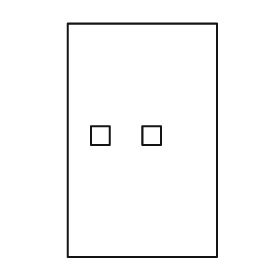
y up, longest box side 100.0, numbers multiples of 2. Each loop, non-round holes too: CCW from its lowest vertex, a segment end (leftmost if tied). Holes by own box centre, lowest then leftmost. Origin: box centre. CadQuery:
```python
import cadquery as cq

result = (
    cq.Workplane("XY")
    .moveTo(-32.0, -50.0)
    .lineTo(32.0, -50.0)
    .lineTo(32.0, 50.0)
    .lineTo(-32.0, 50.0)
    .close()
    .moveTo(-22.0, -2.0)
    .lineTo(-14.0, -2.0)
    .lineTo(-14.0, 6.0)
    .lineTo(-22.0, 6.0)
    .close()
    .moveTo(0.0, -2.0)
    .lineTo(8.0, -2.0)
    .lineTo(8.0, 6.0)
    .lineTo(0.0, 6.0)
    .close()
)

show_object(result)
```